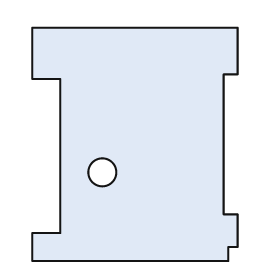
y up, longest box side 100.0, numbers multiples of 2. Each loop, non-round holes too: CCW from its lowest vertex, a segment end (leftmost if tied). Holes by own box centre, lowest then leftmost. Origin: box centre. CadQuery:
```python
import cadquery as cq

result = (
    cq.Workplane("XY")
    .moveTo(-44.0, -50.0)
    .lineTo(40.0, -50.0)
    .lineTo(40.0, -44.0)
    .lineTo(44.0, -44.0)
    .lineTo(44.0, -30.0)
    .lineTo(38.0, -30.0)
    .lineTo(38.0, 30.0)
    .lineTo(44.0, 30.0)
    .lineTo(44.0, 50.0)
    .lineTo(-44.0, 50.0)
    .lineTo(-44.0, 28.0)
    .lineTo(-32.0, 28.0)
    .lineTo(-32.0, -38.0)
    .lineTo(-44.0, -38.0)
    .close()
    .moveTo(-14.0, -12.0)
    .circle(6.0)
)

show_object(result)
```